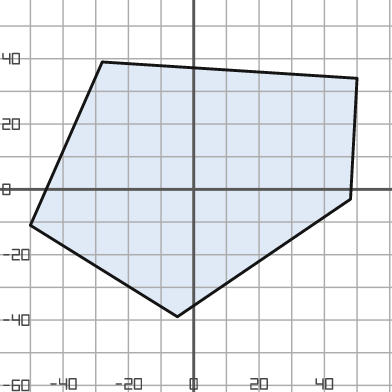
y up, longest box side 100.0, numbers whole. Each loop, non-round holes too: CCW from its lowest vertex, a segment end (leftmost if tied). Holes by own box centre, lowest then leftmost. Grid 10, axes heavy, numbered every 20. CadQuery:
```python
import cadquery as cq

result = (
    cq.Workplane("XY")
    .moveTo(-5.0, -39.0)
    .lineTo(48.0, -3.0)
    .lineTo(50.0, 34.0)
    .lineTo(-28.0, 39.0)
    .lineTo(-50.0, -11.0)
    .close()
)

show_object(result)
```